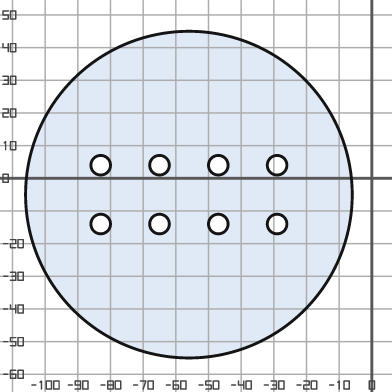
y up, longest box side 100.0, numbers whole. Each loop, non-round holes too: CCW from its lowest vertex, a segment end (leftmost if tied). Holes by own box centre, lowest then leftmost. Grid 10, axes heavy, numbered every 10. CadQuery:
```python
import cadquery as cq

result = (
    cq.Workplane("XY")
    .moveTo(-56.0, -5.0)
    .circle(50.0)
    .moveTo(-83.0, -14.0)
    .circle(3.0)
    .moveTo(-65.0, -14.0)
    .circle(3.0)
    .moveTo(-47.0, -14.0)
    .circle(3.0)
    .moveTo(-29.0, -14.0)
    .circle(3.0)
    .moveTo(-83.0, 4.0)
    .circle(3.0)
    .moveTo(-65.0, 4.0)
    .circle(3.0)
    .moveTo(-47.0, 4.0)
    .circle(3.0)
    .moveTo(-29.0, 4.0)
    .circle(3.0)
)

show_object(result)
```